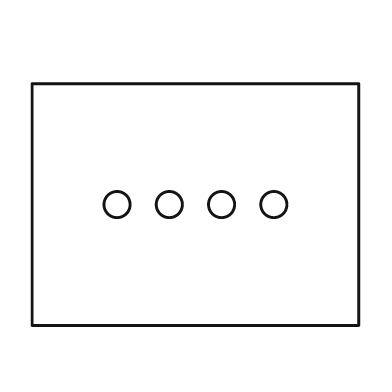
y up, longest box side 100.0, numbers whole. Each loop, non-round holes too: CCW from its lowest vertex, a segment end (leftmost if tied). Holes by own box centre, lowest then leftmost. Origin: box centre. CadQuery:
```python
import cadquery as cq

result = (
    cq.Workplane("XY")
    .moveTo(-50.0, -37.0)
    .lineTo(50.0, -37.0)
    .lineTo(50.0, 37.0)
    .lineTo(-50.0, 37.0)
    .close()
    .moveTo(-24.0, 0.0)
    .circle(4.0)
    .moveTo(-8.0, 0.0)
    .circle(4.0)
    .moveTo(8.0, 0.0)
    .circle(4.0)
    .moveTo(24.0, 0.0)
    .circle(4.0)
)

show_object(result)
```